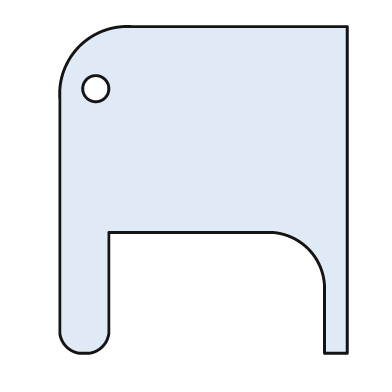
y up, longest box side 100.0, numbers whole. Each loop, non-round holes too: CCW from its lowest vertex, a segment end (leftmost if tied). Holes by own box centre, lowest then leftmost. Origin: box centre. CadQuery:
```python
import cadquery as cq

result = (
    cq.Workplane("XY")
    .moveTo(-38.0, -50.0)
    .lineTo(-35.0, -50.0)
    .threePointArc((-31.0, -48.0), (-29.0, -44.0))
    .lineTo(-29.0, -13.0)
    .lineTo(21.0, -13.0)
    .threePointArc((32.0, -18.0), (37.0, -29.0))
    .lineTo(37.0, -50.0)
    .lineTo(44.0, -50.0)
    .lineTo(44.0, 50.0)
    .lineTo(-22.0, 50.0)
    .threePointArc((-38.0, 44.0), (-44.0, 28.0))
    .lineTo(-44.0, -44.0)
    .threePointArc((-42.0, -48.0), (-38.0, -50.0))
    .close()
    .moveTo(-33.0, 31.0)
    .circle(4.0)
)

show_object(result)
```